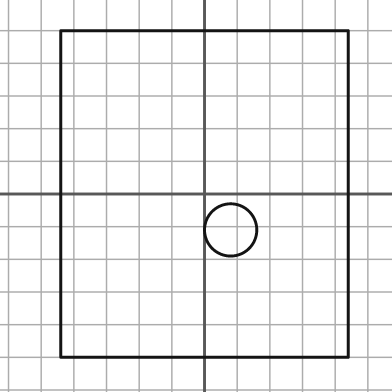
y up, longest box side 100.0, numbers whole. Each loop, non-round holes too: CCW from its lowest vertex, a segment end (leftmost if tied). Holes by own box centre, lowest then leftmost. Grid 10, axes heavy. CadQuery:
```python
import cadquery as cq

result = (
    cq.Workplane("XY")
    .moveTo(-44.0, -50.0)
    .lineTo(44.0, -50.0)
    .lineTo(44.0, 50.0)
    .lineTo(-44.0, 50.0)
    .close()
    .moveTo(8.0, -11.0)
    .circle(8.0)
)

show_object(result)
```